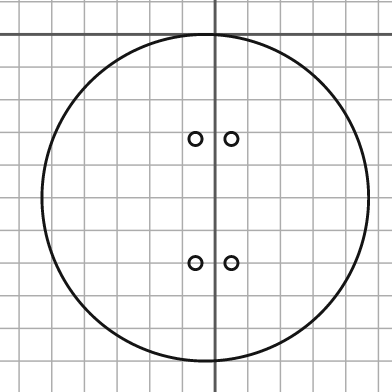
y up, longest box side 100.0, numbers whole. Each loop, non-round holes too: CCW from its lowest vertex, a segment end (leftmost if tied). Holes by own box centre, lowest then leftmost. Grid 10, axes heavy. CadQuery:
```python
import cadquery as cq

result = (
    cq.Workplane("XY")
    .moveTo(-3.0, -50.0)
    .circle(50.0)
    .moveTo(-6.0, -70.0)
    .circle(2.0)
    .moveTo(5.0, -70.0)
    .circle(2.0)
    .moveTo(-6.0, -32.0)
    .circle(2.0)
    .moveTo(5.0, -32.0)
    .circle(2.0)
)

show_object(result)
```